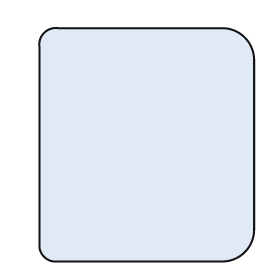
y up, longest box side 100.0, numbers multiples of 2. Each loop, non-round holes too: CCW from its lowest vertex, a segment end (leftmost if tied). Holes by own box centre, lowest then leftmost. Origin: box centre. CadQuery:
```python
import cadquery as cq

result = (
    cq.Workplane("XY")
    .moveTo(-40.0, -50.0)
    .lineTo(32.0, -50.0)
    .threePointArc((42.0, -46.0), (46.0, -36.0))
    .lineTo(46.0, 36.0)
    .threePointArc((42.0, 46.0), (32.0, 50.0))
    .lineTo(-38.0, 50.0)
    .threePointArc((-44.0, 48.0), (-46.0, 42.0))
    .lineTo(-46.0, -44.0)
    .threePointArc((-44.0, -48.0), (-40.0, -50.0))
    .close()
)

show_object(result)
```